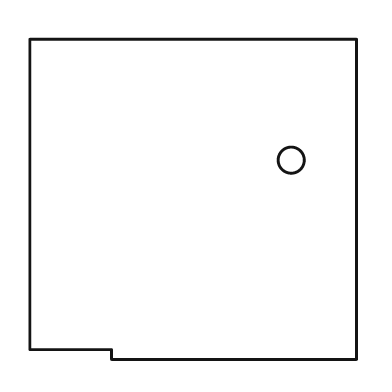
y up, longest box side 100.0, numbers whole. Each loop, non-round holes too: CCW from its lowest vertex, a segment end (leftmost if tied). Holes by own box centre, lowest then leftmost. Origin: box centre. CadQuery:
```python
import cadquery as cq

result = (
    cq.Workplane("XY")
    .moveTo(-25.0, -49.0)
    .lineTo(50.0, -49.0)
    .lineTo(50.0, 49.0)
    .lineTo(-50.0, 49.0)
    .lineTo(-50.0, -46.0)
    .lineTo(-25.0, -46.0)
    .close()
    .moveTo(30.0, 12.0)
    .circle(4.0)
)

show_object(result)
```